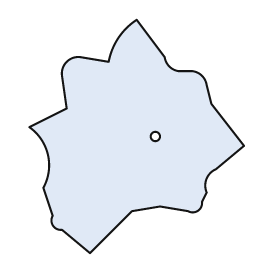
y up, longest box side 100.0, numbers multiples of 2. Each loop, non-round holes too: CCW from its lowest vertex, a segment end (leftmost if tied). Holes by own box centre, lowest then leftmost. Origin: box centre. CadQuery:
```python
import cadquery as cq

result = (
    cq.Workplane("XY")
    .moveTo(-20.0, -50.0)
    .lineTo(-2.0, -32.0)
    .lineTo(10.0, -30.0)
    .lineTo(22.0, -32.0)
    .threePointArc((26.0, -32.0), (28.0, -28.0))
    .lineTo(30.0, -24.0)
    .threePointArc((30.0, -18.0), (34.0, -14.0))
    .lineTo(46.0, -4.0)
    .lineTo(32.0, 14.0)
    .lineTo(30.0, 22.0)
    .threePointArc((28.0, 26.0), (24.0, 28.0))
    .lineTo(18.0, 28.0)
    .threePointArc((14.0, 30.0), (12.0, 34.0))
    .lineTo(0.0, 50.0)
    .threePointArc((-8.0, 42.0), (-12.0, 32.0))
    .lineTo(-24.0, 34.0)
    .threePointArc((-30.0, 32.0), (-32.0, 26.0))
    .lineTo(-30.0, 12.0)
    .lineTo(-46.0, 4.0)
    .threePointArc((-38.0, -8.0), (-40.0, -22.0))
    .lineTo(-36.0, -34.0)
    .threePointArc((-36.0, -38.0), (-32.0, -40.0))
    .close()
    .moveTo(8.0, 0.0)
    .circle(2.0)
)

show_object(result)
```